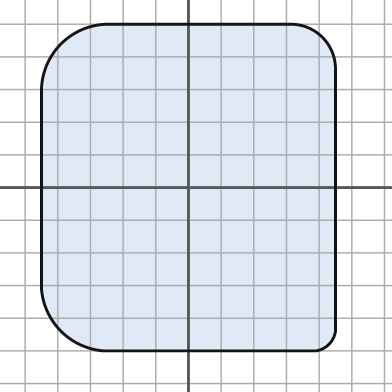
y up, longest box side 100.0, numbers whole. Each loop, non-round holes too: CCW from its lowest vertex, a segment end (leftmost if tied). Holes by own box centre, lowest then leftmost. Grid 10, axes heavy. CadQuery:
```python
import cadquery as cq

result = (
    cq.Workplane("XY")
    .moveTo(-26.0, -50.0)
    .lineTo(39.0, -50.0)
    .threePointArc((43.0, -48.0), (45.0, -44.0))
    .lineTo(45.0, 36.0)
    .threePointArc((41.0, 46.0), (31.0, 50.0))
    .lineTo(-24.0, 50.0)
    .threePointArc((-39.0, 44.0), (-45.0, 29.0))
    .lineTo(-45.0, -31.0)
    .threePointArc((-39.0, -44.0), (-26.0, -50.0))
    .close()
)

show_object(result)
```